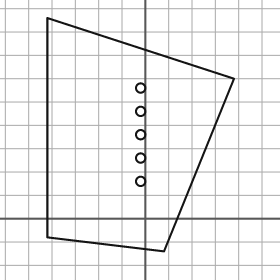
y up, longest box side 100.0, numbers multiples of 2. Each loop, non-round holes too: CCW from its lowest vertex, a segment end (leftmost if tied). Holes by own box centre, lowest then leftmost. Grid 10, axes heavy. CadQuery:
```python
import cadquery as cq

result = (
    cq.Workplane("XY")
    .moveTo(8.0, -14.0)
    .lineTo(38.0, 60.0)
    .lineTo(-42.0, 86.0)
    .lineTo(-42.0, -8.0)
    .close()
    .moveTo(-2.0, 16.0)
    .circle(2.0)
    .moveTo(-2.0, 26.0)
    .circle(2.0)
    .moveTo(-2.0, 36.0)
    .circle(2.0)
    .moveTo(-2.0, 46.0)
    .circle(2.0)
    .moveTo(-2.0, 56.0)
    .circle(2.0)
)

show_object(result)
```